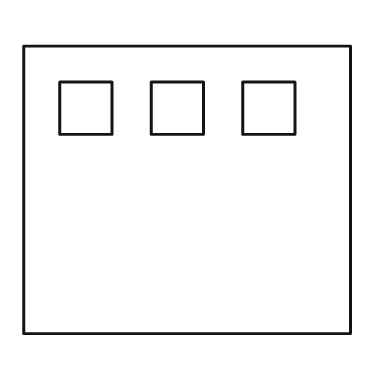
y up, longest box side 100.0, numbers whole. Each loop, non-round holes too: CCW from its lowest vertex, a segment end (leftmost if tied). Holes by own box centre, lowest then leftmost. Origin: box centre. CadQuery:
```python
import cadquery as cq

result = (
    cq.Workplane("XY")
    .moveTo(-50.0, -44.0)
    .lineTo(50.0, -44.0)
    .lineTo(50.0, 44.0)
    .lineTo(-50.0, 44.0)
    .close()
    .moveTo(-39.0, 17.0)
    .lineTo(-23.0, 17.0)
    .lineTo(-23.0, 33.0)
    .lineTo(-39.0, 33.0)
    .close()
    .moveTo(-11.0, 17.0)
    .lineTo(5.0, 17.0)
    .lineTo(5.0, 33.0)
    .lineTo(-11.0, 33.0)
    .close()
    .moveTo(17.0, 17.0)
    .lineTo(33.0, 17.0)
    .lineTo(33.0, 33.0)
    .lineTo(17.0, 33.0)
    .close()
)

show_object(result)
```